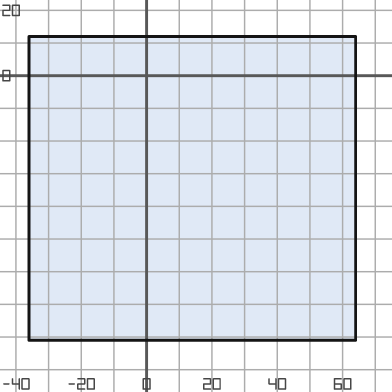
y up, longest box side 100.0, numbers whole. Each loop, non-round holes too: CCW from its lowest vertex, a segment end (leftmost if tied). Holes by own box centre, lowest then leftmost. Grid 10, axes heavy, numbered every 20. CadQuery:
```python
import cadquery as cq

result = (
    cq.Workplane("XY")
    .moveTo(-36.0, -81.0)
    .lineTo(64.0, -81.0)
    .lineTo(64.0, 12.0)
    .lineTo(-36.0, 12.0)
    .close()
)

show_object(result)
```